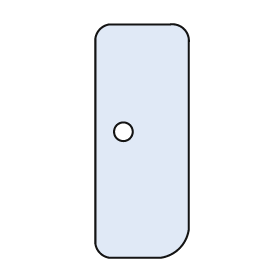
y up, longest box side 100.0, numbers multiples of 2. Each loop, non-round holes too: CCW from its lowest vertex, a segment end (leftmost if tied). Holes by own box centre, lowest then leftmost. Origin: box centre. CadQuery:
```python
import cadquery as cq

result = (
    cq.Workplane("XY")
    .moveTo(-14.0, -50.0)
    .lineTo(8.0, -50.0)
    .threePointArc((16.0, -46.0), (20.0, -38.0))
    .lineTo(20.0, 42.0)
    .threePointArc((18.0, 48.0), (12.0, 50.0))
    .lineTo(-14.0, 50.0)
    .threePointArc((-18.0, 48.0), (-20.0, 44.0))
    .lineTo(-20.0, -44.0)
    .threePointArc((-18.0, -48.0), (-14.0, -50.0))
    .close()
    .moveTo(-8.0, 4.0)
    .circle(4.0)
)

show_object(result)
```